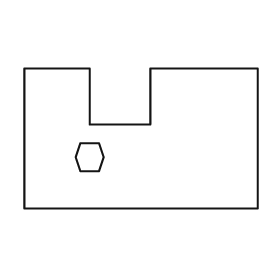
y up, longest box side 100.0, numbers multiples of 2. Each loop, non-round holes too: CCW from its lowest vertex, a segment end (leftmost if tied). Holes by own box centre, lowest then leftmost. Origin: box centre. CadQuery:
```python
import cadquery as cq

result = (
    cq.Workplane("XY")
    .moveTo(-50.0, -30.0)
    .lineTo(50.0, -30.0)
    .lineTo(50.0, 30.0)
    .lineTo(4.0, 30.0)
    .lineTo(4.0, 6.0)
    .lineTo(-22.0, 6.0)
    .lineTo(-22.0, 30.0)
    .lineTo(-50.0, 30.0)
    .close()
    .moveTo(-26.0, -14.0)
    .lineTo(-18.0, -14.0)
    .lineTo(-16.0, -8.0)
    .lineTo(-18.0, -2.0)
    .lineTo(-26.0, -2.0)
    .lineTo(-28.0, -8.0)
    .close()
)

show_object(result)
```